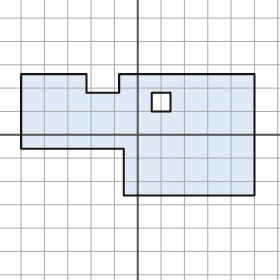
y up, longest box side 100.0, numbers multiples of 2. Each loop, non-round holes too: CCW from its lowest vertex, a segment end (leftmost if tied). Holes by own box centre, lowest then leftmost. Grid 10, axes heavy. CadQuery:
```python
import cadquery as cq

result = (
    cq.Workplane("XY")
    .moveTo(-6.0, -26.0)
    .lineTo(50.0, -26.0)
    .lineTo(50.0, 26.0)
    .lineTo(-8.0, 26.0)
    .lineTo(-8.0, 18.0)
    .lineTo(-22.0, 18.0)
    .lineTo(-22.0, 26.0)
    .lineTo(-50.0, 26.0)
    .lineTo(-50.0, -6.0)
    .lineTo(-6.0, -6.0)
    .close()
    .moveTo(6.0, 10.0)
    .lineTo(14.0, 10.0)
    .lineTo(14.0, 18.0)
    .lineTo(6.0, 18.0)
    .close()
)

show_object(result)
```